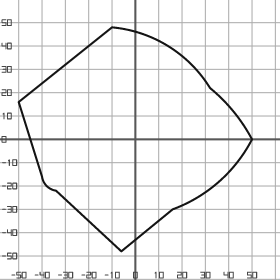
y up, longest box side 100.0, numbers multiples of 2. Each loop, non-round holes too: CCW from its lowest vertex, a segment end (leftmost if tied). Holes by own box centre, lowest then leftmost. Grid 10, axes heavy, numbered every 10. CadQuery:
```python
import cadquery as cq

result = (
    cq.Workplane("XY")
    .moveTo(-6.0, -48.0)
    .lineTo(16.0, -30.0)
    .threePointArc((36.0, -18.0), (50.0, 0.0))
    .threePointArc((42.0, 12.0), (32.0, 22.0))
    .threePointArc((14.0, 40.0), (-10.0, 48.0))
    .lineTo(-50.0, 16.0)
    .lineTo(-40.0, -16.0)
    .threePointArc((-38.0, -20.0), (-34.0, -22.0))
    .close()
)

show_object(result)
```